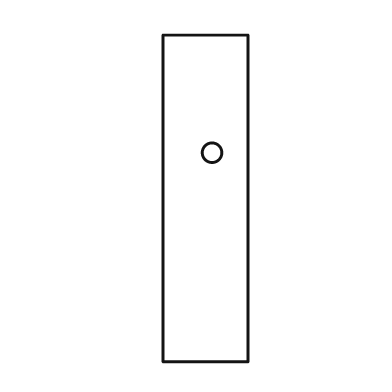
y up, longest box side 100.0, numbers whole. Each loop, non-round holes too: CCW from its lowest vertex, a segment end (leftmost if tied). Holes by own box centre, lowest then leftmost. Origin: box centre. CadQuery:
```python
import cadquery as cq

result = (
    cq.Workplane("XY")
    .moveTo(-13.0, -50.0)
    .lineTo(13.0, -50.0)
    .lineTo(13.0, 50.0)
    .lineTo(-13.0, 50.0)
    .close()
    .moveTo(2.0, 14.0)
    .circle(3.0)
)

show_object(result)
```